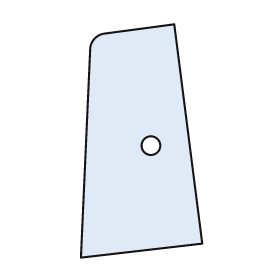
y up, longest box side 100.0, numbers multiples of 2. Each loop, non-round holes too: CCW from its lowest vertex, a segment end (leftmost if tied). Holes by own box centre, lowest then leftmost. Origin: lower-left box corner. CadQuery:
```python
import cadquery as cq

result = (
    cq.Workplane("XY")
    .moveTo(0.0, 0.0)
    .lineTo(52.0, 6.0)
    .lineTo(40.0, 100.0)
    .lineTo(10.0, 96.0)
    .threePointArc((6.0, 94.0), (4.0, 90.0))
    .close()
    .moveTo(30.0, 48.0)
    .circle(4.0)
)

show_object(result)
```